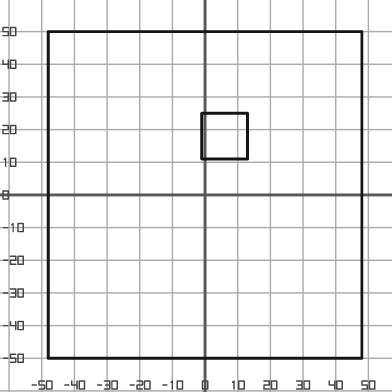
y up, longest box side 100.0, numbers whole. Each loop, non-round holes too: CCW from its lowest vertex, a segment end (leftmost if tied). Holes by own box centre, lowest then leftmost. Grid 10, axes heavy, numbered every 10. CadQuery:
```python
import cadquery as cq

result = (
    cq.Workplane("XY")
    .moveTo(-48.0, -50.0)
    .lineTo(48.0, -50.0)
    .lineTo(48.0, 50.0)
    .lineTo(-48.0, 50.0)
    .close()
    .moveTo(-1.0, 11.0)
    .lineTo(13.0, 11.0)
    .lineTo(13.0, 25.0)
    .lineTo(-1.0, 25.0)
    .close()
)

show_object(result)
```